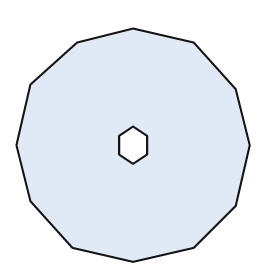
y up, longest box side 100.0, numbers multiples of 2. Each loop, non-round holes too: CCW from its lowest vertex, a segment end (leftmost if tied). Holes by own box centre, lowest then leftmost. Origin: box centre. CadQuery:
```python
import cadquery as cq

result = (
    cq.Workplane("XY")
    .moveTo(0.0, -50.0)
    .lineTo(26.0, -44.0)
    .lineTo(44.0, -26.0)
    .lineTo(50.0, 0.0)
    .lineTo(44.0, 24.0)
    .lineTo(26.0, 44.0)
    .lineTo(0.0, 50.0)
    .lineTo(-24.0, 44.0)
    .lineTo(-44.0, 26.0)
    .lineTo(-50.0, 0.0)
    .lineTo(-44.0, -24.0)
    .lineTo(-26.0, -44.0)
    .close()
    .moveTo(0.0, -8.0)
    .lineTo(6.0, -4.0)
    .lineTo(6.0, 4.0)
    .lineTo(0.0, 8.0)
    .lineTo(-6.0, 4.0)
    .lineTo(-6.0, -4.0)
    .close()
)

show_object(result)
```